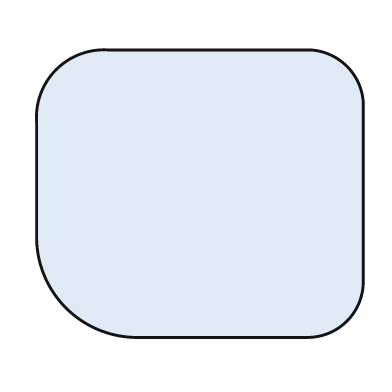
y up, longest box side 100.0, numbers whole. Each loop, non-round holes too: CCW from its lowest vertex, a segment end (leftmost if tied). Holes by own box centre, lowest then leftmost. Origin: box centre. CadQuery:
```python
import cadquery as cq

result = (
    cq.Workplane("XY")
    .moveTo(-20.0, -44.0)
    .lineTo(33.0, -44.0)
    .threePointArc((45.0, -39.0), (50.0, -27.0))
    .lineTo(50.0, 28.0)
    .threePointArc((45.0, 39.0), (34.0, 44.0))
    .lineTo(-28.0, 44.0)
    .threePointArc((-44.0, 38.0), (-50.0, 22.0))
    .lineTo(-50.0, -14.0)
    .threePointArc((-41.0, -35.0), (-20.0, -44.0))
    .close()
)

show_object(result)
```